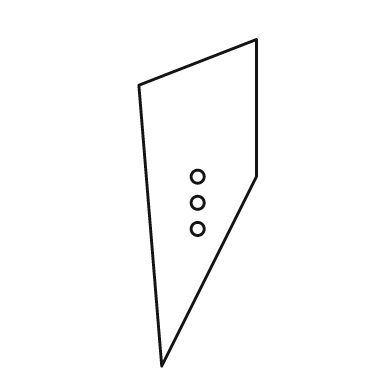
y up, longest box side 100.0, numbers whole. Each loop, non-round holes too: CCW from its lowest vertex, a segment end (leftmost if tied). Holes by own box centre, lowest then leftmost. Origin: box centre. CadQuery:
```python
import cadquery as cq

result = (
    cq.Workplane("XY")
    .moveTo(-11.0, -50.0)
    .lineTo(18.0, 8.0)
    .lineTo(18.0, 50.0)
    .lineTo(-18.0, 36.0)
    .close()
    .moveTo(0.0, -8.0)
    .circle(2.0)
    .moveTo(0.0, 0.0)
    .circle(2.0)
    .moveTo(0.0, 8.0)
    .circle(2.0)
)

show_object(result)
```